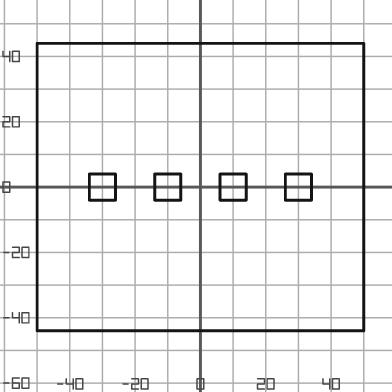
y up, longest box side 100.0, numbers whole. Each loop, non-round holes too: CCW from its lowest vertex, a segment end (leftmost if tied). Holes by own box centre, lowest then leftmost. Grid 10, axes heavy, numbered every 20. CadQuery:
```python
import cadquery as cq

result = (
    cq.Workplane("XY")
    .moveTo(-50.0, -44.0)
    .lineTo(50.0, -44.0)
    .lineTo(50.0, 44.0)
    .lineTo(-50.0, 44.0)
    .close()
    .moveTo(-34.0, -4.0)
    .lineTo(-26.0, -4.0)
    .lineTo(-26.0, 4.0)
    .lineTo(-34.0, 4.0)
    .close()
    .moveTo(-14.0, -4.0)
    .lineTo(-6.0, -4.0)
    .lineTo(-6.0, 4.0)
    .lineTo(-14.0, 4.0)
    .close()
    .moveTo(6.0, -4.0)
    .lineTo(14.0, -4.0)
    .lineTo(14.0, 4.0)
    .lineTo(6.0, 4.0)
    .close()
    .moveTo(26.0, -4.0)
    .lineTo(34.0, -4.0)
    .lineTo(34.0, 4.0)
    .lineTo(26.0, 4.0)
    .close()
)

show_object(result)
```